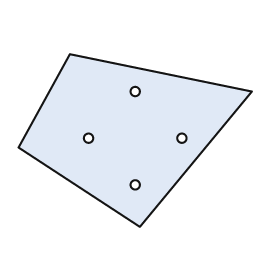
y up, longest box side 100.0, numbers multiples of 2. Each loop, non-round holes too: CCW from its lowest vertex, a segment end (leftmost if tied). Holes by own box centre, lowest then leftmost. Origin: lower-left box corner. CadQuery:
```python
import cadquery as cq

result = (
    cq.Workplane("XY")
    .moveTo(52.0, 0.0)
    .lineTo(100.0, 58.0)
    .lineTo(22.0, 74.0)
    .lineTo(0.0, 34.0)
    .close()
    .moveTo(50.0, 18.0)
    .circle(2.0)
    .moveTo(30.0, 38.0)
    .circle(2.0)
    .moveTo(70.0, 38.0)
    .circle(2.0)
    .moveTo(50.0, 58.0)
    .circle(2.0)
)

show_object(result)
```